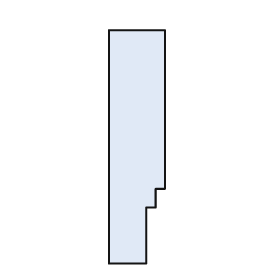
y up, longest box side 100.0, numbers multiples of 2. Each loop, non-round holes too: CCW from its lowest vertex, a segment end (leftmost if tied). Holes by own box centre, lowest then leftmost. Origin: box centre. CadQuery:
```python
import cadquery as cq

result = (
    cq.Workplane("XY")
    .moveTo(-12.0, -50.0)
    .lineTo(4.0, -50.0)
    .lineTo(4.0, -26.0)
    .lineTo(8.0, -26.0)
    .lineTo(8.0, -18.0)
    .lineTo(12.0, -18.0)
    .lineTo(12.0, 50.0)
    .lineTo(-12.0, 50.0)
    .close()
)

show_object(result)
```